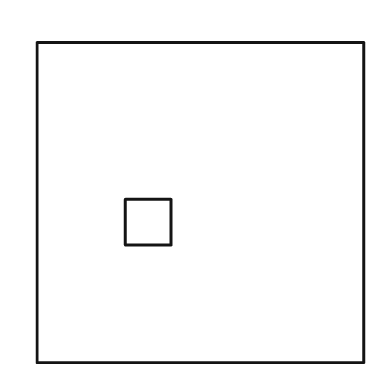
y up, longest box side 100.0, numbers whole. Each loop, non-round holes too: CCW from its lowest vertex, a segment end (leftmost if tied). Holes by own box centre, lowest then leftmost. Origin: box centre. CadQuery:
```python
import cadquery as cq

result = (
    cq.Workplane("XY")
    .moveTo(-50.0, -49.0)
    .lineTo(50.0, -49.0)
    .lineTo(50.0, 49.0)
    .lineTo(-50.0, 49.0)
    .close()
    .moveTo(-23.0, -13.0)
    .lineTo(-9.0, -13.0)
    .lineTo(-9.0, 1.0)
    .lineTo(-23.0, 1.0)
    .close()
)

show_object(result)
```